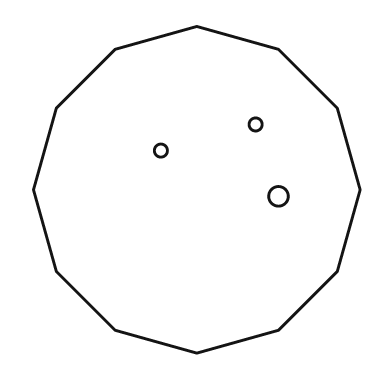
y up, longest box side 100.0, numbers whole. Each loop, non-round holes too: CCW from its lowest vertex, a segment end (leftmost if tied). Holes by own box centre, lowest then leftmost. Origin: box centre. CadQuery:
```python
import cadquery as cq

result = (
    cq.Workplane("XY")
    .moveTo(0.0, -50.0)
    .lineTo(25.0, -43.0)
    .lineTo(43.0, -25.0)
    .lineTo(50.0, 0.0)
    .lineTo(43.0, 25.0)
    .lineTo(25.0, 43.0)
    .lineTo(0.0, 50.0)
    .lineTo(-25.0, 43.0)
    .lineTo(-43.0, 25.0)
    .lineTo(-50.0, 0.0)
    .lineTo(-43.0, -25.0)
    .lineTo(-25.0, -43.0)
    .close()
    .moveTo(25.0, -2.0)
    .circle(3.0)
    .moveTo(-11.0, 12.0)
    .circle(2.0)
    .moveTo(18.0, 20.0)
    .circle(2.0)
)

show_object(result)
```